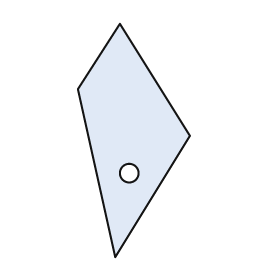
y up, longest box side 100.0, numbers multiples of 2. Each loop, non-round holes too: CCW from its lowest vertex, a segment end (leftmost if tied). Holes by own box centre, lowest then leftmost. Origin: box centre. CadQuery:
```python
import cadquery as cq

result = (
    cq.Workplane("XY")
    .moveTo(-8.0, -50.0)
    .lineTo(24.0, 2.0)
    .lineTo(-6.0, 50.0)
    .lineTo(-24.0, 22.0)
    .close()
    .moveTo(-2.0, -14.0)
    .circle(4.0)
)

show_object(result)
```